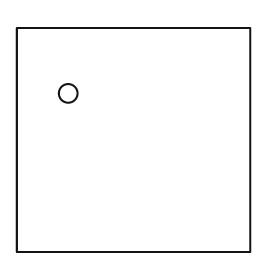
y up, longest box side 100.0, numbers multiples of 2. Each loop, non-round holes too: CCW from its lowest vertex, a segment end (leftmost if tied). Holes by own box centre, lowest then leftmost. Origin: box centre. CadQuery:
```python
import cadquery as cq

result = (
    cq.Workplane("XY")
    .moveTo(-50.0, -48.0)
    .lineTo(50.0, -48.0)
    .lineTo(50.0, 48.0)
    .lineTo(-50.0, 48.0)
    .close()
    .moveTo(-28.0, 20.0)
    .circle(4.0)
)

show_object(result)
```